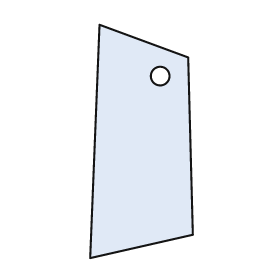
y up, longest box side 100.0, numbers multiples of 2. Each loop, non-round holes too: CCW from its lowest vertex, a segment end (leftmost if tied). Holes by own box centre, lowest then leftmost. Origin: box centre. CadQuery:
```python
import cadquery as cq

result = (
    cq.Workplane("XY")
    .moveTo(-22.0, -50.0)
    .lineTo(22.0, -40.0)
    .lineTo(20.0, 36.0)
    .lineTo(-18.0, 50.0)
    .close()
    .moveTo(8.0, 28.0)
    .circle(4.0)
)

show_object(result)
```